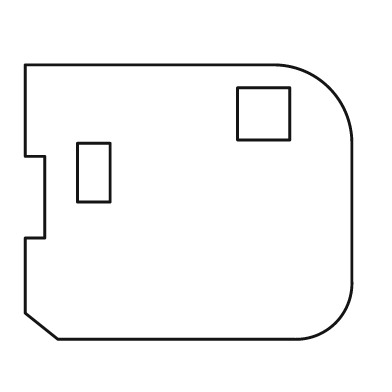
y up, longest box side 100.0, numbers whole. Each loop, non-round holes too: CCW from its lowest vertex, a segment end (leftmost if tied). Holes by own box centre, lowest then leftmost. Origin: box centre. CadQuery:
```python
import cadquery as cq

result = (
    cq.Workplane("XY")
    .moveTo(-40.0, -42.0)
    .lineTo(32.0, -42.0)
    .threePointArc((45.0, -37.0), (50.0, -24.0))
    .lineTo(50.0, 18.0)
    .threePointArc((43.0, 35.0), (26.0, 42.0))
    .lineTo(-50.0, 42.0)
    .lineTo(-50.0, 14.0)
    .lineTo(-44.0, 14.0)
    .lineTo(-44.0, -11.0)
    .lineTo(-50.0, -11.0)
    .lineTo(-50.0, -34.0)
    .close()
    .moveTo(-34.0, 0.0)
    .lineTo(-24.0, 0.0)
    .lineTo(-24.0, 18.0)
    .lineTo(-34.0, 18.0)
    .close()
    .moveTo(15.0, 19.0)
    .lineTo(31.0, 19.0)
    .lineTo(31.0, 35.0)
    .lineTo(15.0, 35.0)
    .close()
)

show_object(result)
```